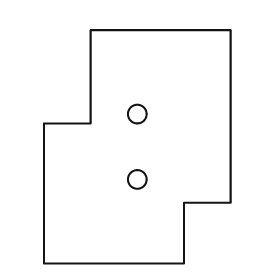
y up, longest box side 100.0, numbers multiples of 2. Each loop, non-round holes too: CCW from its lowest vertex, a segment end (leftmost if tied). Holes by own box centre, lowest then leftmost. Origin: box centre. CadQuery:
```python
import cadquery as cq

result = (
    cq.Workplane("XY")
    .moveTo(-40.0, -50.0)
    .lineTo(20.0, -50.0)
    .lineTo(20.0, -24.0)
    .lineTo(40.0, -24.0)
    .lineTo(40.0, 50.0)
    .lineTo(-20.0, 50.0)
    .lineTo(-20.0, 10.0)
    .lineTo(-40.0, 10.0)
    .close()
    .moveTo(0.0, -14.0)
    .circle(4.0)
    .moveTo(0.0, 14.0)
    .circle(4.0)
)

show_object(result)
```